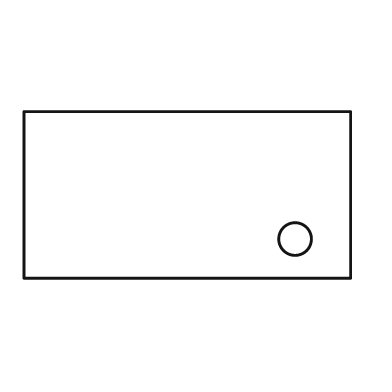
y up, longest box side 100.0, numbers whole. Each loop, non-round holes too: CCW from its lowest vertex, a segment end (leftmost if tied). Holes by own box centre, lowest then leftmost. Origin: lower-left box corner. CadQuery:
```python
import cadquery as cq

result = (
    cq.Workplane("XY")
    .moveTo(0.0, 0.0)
    .lineTo(100.0, 0.0)
    .lineTo(100.0, 51.0)
    .lineTo(0.0, 51.0)
    .close()
    .moveTo(83.0, 12.0)
    .circle(5.0)
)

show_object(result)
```